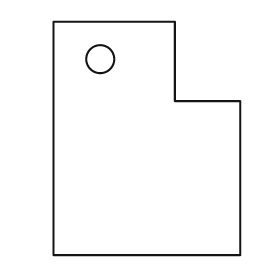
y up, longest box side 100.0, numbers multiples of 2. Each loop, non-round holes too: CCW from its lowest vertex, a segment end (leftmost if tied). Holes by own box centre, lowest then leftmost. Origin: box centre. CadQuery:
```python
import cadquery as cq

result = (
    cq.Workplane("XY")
    .moveTo(-40.0, -50.0)
    .lineTo(40.0, -50.0)
    .lineTo(40.0, 16.0)
    .lineTo(12.0, 16.0)
    .lineTo(12.0, 50.0)
    .lineTo(-40.0, 50.0)
    .close()
    .moveTo(-20.0, 34.0)
    .circle(6.0)
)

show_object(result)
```